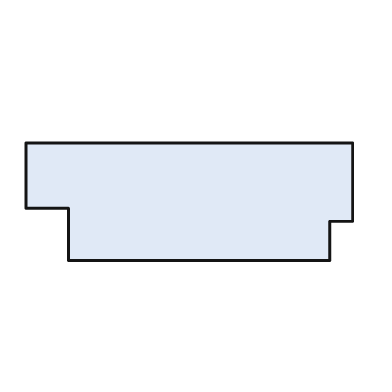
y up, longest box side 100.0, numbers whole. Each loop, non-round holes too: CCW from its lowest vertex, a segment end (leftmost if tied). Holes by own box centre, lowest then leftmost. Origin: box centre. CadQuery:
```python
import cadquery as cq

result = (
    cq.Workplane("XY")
    .moveTo(-37.0, -18.0)
    .lineTo(43.0, -18.0)
    .lineTo(43.0, -6.0)
    .lineTo(50.0, -6.0)
    .lineTo(50.0, 18.0)
    .lineTo(-50.0, 18.0)
    .lineTo(-50.0, -2.0)
    .lineTo(-37.0, -2.0)
    .close()
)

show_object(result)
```